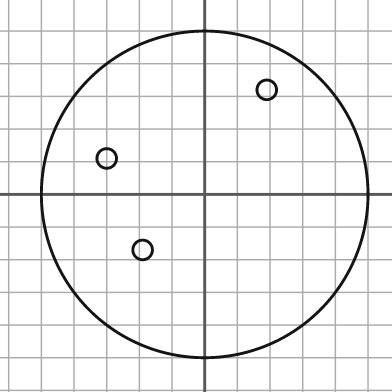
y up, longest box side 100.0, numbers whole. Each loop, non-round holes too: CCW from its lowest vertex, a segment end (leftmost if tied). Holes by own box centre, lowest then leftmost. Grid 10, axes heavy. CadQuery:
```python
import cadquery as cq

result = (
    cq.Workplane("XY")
    .moveTo(0.0, 0.0)
    .circle(50.0)
    .moveTo(-19.0, -17.0)
    .circle(3.0)
    .moveTo(-30.0, 11.0)
    .circle(3.0)
    .moveTo(19.0, 32.0)
    .circle(3.0)
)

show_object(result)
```